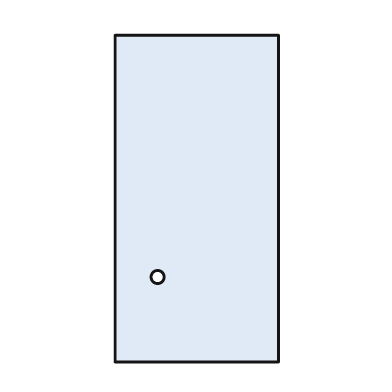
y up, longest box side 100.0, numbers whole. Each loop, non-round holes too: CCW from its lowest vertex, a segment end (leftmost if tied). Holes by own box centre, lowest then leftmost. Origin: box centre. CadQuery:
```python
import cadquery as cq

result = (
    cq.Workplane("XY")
    .moveTo(-25.0, -50.0)
    .lineTo(25.0, -50.0)
    .lineTo(25.0, 50.0)
    .lineTo(-25.0, 50.0)
    .close()
    .moveTo(-12.0, -24.0)
    .circle(2.0)
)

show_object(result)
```